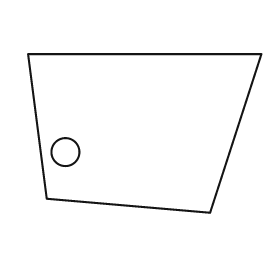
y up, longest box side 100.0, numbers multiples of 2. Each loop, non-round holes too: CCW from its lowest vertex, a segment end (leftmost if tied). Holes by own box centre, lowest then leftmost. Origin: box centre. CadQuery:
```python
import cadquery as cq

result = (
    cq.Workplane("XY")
    .moveTo(28.0, -34.0)
    .lineTo(50.0, 34.0)
    .lineTo(-50.0, 34.0)
    .lineTo(-42.0, -28.0)
    .close()
    .moveTo(-34.0, -8.0)
    .circle(6.0)
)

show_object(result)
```